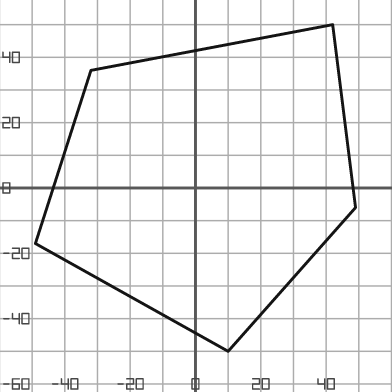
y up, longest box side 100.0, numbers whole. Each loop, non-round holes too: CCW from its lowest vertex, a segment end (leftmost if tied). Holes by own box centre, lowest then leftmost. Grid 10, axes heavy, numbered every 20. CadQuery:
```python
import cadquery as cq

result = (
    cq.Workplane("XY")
    .moveTo(10.0, -50.0)
    .lineTo(49.0, -6.0)
    .lineTo(42.0, 50.0)
    .lineTo(-32.0, 36.0)
    .lineTo(-49.0, -17.0)
    .close()
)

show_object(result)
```